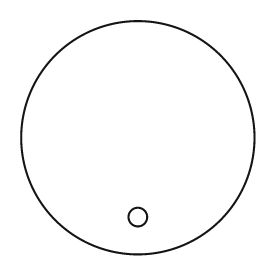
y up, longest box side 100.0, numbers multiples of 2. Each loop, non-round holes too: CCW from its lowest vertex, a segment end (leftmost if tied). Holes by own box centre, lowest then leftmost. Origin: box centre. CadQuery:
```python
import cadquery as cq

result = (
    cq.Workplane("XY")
    .moveTo(0.0, 0.0)
    .circle(50.0)
    .moveTo(0.0, -34.0)
    .circle(4.0)
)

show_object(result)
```